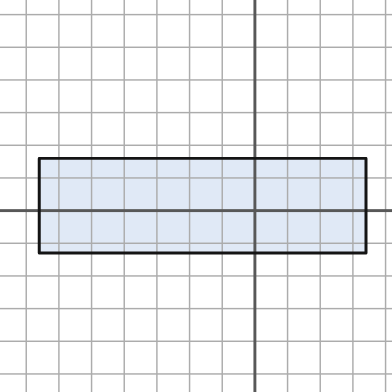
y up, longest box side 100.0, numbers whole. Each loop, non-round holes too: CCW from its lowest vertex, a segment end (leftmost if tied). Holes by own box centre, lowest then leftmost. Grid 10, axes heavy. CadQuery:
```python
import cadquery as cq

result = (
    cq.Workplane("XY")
    .moveTo(-66.0, -13.0)
    .lineTo(34.0, -13.0)
    .lineTo(34.0, 16.0)
    .lineTo(-66.0, 16.0)
    .close()
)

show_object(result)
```